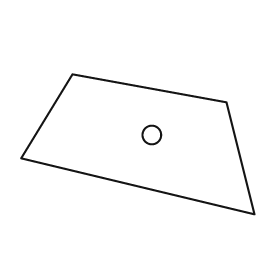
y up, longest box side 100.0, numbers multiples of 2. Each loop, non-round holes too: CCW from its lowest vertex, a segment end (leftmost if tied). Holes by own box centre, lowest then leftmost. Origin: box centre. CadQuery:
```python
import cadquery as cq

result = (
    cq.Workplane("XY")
    .moveTo(50.0, -30.0)
    .lineTo(38.0, 18.0)
    .lineTo(-28.0, 30.0)
    .lineTo(-50.0, -6.0)
    .close()
    .moveTo(6.0, 4.0)
    .circle(4.0)
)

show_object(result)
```